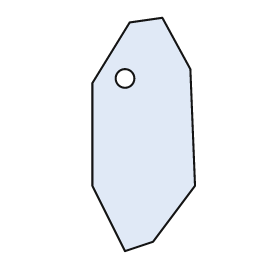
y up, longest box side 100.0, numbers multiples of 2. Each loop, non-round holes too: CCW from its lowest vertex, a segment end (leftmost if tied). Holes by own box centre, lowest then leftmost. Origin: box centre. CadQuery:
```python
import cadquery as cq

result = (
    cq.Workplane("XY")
    .moveTo(-8.0, -50.0)
    .lineTo(4.0, -46.0)
    .lineTo(22.0, -22.0)
    .lineTo(20.0, 28.0)
    .lineTo(8.0, 50.0)
    .lineTo(-6.0, 48.0)
    .lineTo(-22.0, 22.0)
    .lineTo(-22.0, -22.0)
    .close()
    .moveTo(-8.0, 24.0)
    .circle(4.0)
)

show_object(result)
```